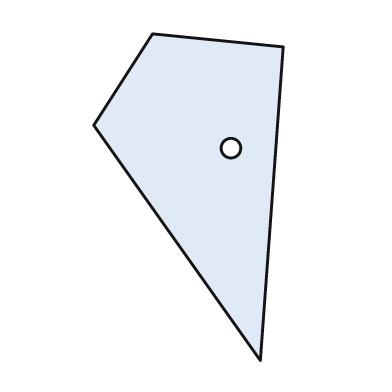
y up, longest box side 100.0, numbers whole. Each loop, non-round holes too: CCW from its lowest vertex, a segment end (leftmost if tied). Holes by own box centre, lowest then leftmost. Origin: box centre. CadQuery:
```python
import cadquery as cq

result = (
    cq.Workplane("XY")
    .moveTo(22.0, -50.0)
    .lineTo(29.0, 46.0)
    .lineTo(-11.0, 50.0)
    .lineTo(-29.0, 22.0)
    .close()
    .moveTo(13.0, 15.0)
    .circle(3.0)
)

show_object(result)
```